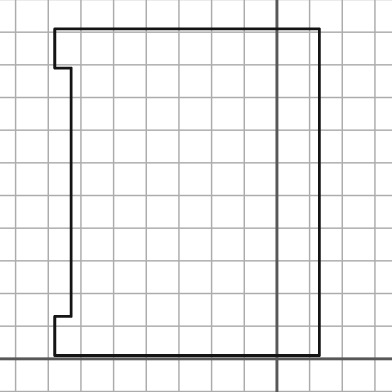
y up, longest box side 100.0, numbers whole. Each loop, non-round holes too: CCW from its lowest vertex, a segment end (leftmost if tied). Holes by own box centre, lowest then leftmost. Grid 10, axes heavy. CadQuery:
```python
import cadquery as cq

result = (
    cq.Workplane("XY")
    .moveTo(-68.0, 1.0)
    .lineTo(13.0, 1.0)
    .lineTo(13.0, 101.0)
    .lineTo(-68.0, 101.0)
    .lineTo(-68.0, 89.0)
    .lineTo(-63.0, 89.0)
    .lineTo(-63.0, 13.0)
    .lineTo(-68.0, 13.0)
    .close()
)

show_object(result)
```